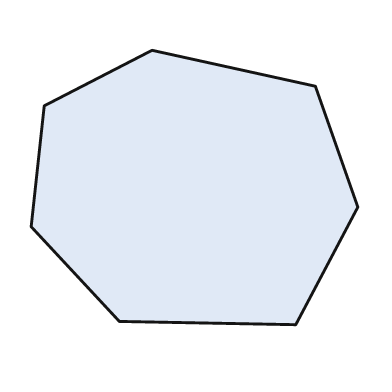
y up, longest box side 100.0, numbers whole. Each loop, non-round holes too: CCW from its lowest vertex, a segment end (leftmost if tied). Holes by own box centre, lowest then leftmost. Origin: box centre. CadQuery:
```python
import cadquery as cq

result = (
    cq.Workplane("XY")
    .moveTo(31.0, -42.0)
    .lineTo(50.0, -6.0)
    .lineTo(37.0, 31.0)
    .lineTo(-13.0, 42.0)
    .lineTo(-46.0, 25.0)
    .lineTo(-50.0, -12.0)
    .lineTo(-23.0, -41.0)
    .close()
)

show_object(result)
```